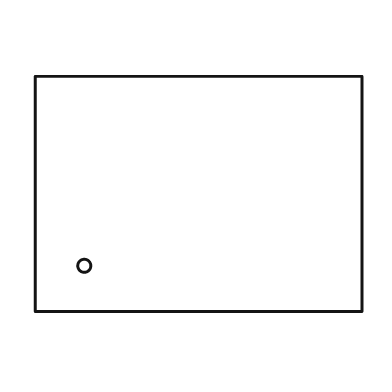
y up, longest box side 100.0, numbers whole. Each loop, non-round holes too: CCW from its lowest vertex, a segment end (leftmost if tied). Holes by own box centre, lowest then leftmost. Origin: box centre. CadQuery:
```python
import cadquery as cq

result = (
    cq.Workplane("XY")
    .moveTo(-50.0, -36.0)
    .lineTo(50.0, -36.0)
    .lineTo(50.0, 36.0)
    .lineTo(-50.0, 36.0)
    .close()
    .moveTo(-35.0, -22.0)
    .circle(2.0)
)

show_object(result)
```